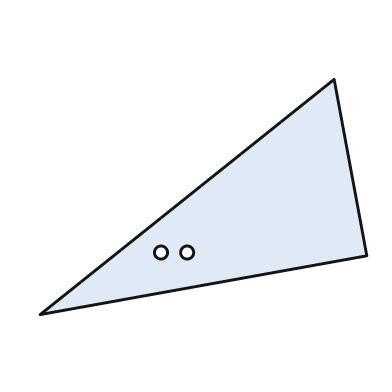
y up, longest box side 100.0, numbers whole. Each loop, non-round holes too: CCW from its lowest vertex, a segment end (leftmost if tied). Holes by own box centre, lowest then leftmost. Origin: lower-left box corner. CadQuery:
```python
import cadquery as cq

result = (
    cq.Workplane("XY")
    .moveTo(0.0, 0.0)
    .lineTo(100.0, 18.0)
    .lineTo(90.0, 72.0)
    .close()
    .moveTo(37.0, 19.0)
    .circle(2.0)
    .moveTo(45.0, 19.0)
    .circle(2.0)
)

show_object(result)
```